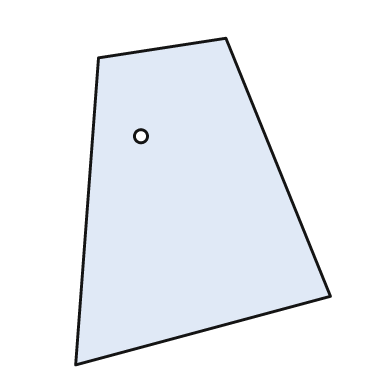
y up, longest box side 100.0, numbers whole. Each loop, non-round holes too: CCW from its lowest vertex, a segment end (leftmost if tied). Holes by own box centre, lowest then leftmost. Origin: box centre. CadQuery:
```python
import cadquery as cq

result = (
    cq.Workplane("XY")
    .moveTo(-39.0, -50.0)
    .lineTo(39.0, -29.0)
    .lineTo(7.0, 50.0)
    .lineTo(-32.0, 44.0)
    .close()
    .moveTo(-19.0, 20.0)
    .circle(2.0)
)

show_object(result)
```